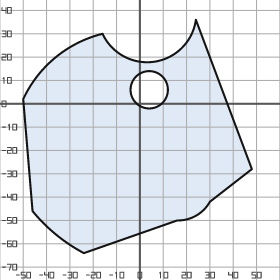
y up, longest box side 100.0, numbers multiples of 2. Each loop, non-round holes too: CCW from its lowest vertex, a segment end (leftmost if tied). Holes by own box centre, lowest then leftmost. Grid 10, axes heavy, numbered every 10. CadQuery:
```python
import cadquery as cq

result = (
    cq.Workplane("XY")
    .moveTo(-24.0, -64.0)
    .lineTo(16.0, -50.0)
    .threePointArc((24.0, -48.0), (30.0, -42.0))
    .lineTo(48.0, -28.0)
    .lineTo(24.0, 36.0)
    .threePointArc((6.0, 18.0), (-16.0, 30.0))
    .threePointArc((-36.0, 20.0), (-50.0, 2.0))
    .lineTo(-46.0, -46.0)
    .threePointArc((-36.0, -56.0), (-24.0, -64.0))
    .close()
    .moveTo(4.0, 6.0)
    .circle(8.0)
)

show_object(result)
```